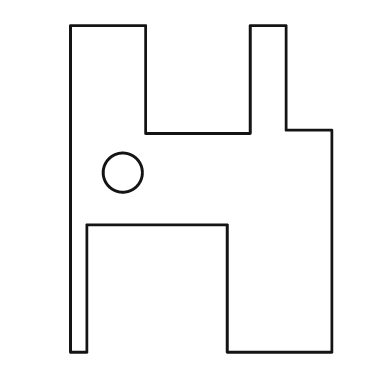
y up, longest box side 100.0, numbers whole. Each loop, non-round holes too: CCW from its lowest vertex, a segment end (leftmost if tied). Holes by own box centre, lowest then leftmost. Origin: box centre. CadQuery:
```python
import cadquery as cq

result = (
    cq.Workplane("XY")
    .moveTo(-40.0, -50.0)
    .lineTo(-35.0, -50.0)
    .lineTo(-35.0, -11.0)
    .lineTo(8.0, -11.0)
    .lineTo(8.0, -50.0)
    .lineTo(40.0, -50.0)
    .lineTo(40.0, 18.0)
    .lineTo(26.0, 18.0)
    .lineTo(26.0, 50.0)
    .lineTo(15.0, 50.0)
    .lineTo(15.0, 17.0)
    .lineTo(-17.0, 17.0)
    .lineTo(-17.0, 50.0)
    .lineTo(-40.0, 50.0)
    .close()
    .moveTo(-24.0, 5.0)
    .circle(6.0)
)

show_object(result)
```